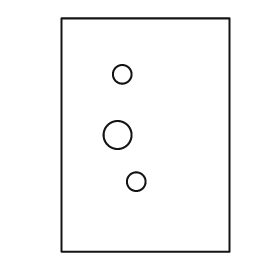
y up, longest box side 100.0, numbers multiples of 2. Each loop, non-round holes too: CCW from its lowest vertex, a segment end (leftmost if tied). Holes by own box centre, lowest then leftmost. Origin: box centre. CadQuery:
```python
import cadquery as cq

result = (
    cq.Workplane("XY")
    .moveTo(-36.0, -50.0)
    .lineTo(36.0, -50.0)
    .lineTo(36.0, 50.0)
    .lineTo(-36.0, 50.0)
    .close()
    .moveTo(-4.0, -20.0)
    .circle(4.0)
    .moveTo(-12.0, 0.0)
    .circle(6.0)
    .moveTo(-10.0, 26.0)
    .circle(4.0)
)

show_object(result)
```